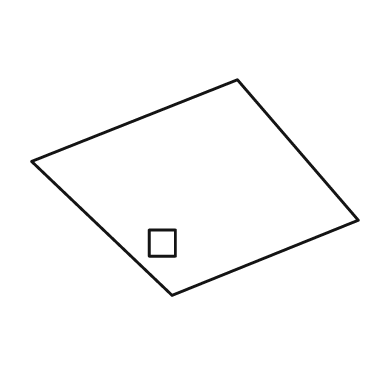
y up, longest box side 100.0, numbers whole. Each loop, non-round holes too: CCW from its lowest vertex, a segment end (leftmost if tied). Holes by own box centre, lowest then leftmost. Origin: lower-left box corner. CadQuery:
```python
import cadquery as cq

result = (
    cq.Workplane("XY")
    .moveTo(43.0, 0.0)
    .lineTo(100.0, 23.0)
    .lineTo(63.0, 66.0)
    .lineTo(0.0, 41.0)
    .close()
    .moveTo(36.0, 12.0)
    .lineTo(44.0, 12.0)
    .lineTo(44.0, 20.0)
    .lineTo(36.0, 20.0)
    .close()
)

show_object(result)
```